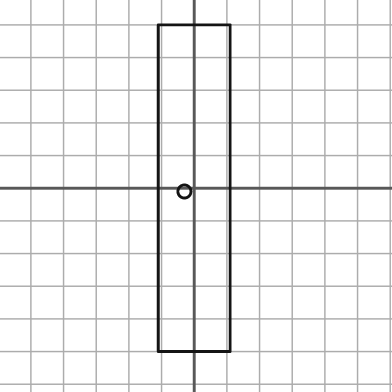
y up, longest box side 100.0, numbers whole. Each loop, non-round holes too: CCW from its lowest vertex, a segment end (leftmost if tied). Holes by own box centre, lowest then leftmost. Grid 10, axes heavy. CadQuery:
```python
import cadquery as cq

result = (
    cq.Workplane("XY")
    .moveTo(-11.0, -50.0)
    .lineTo(11.0, -50.0)
    .lineTo(11.0, 50.0)
    .lineTo(-11.0, 50.0)
    .close()
    .moveTo(-3.0, -1.0)
    .circle(2.0)
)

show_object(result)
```